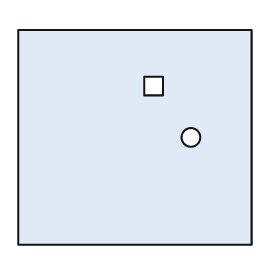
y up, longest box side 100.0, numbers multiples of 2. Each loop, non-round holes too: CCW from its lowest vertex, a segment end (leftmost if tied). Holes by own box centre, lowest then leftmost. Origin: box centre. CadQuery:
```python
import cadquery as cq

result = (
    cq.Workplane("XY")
    .moveTo(-50.0, -46.0)
    .lineTo(50.0, -46.0)
    .lineTo(50.0, 46.0)
    .lineTo(-50.0, 46.0)
    .close()
    .moveTo(24.0, 0.0)
    .circle(4.0)
    .moveTo(4.0, 18.0)
    .lineTo(12.0, 18.0)
    .lineTo(12.0, 26.0)
    .lineTo(4.0, 26.0)
    .close()
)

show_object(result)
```